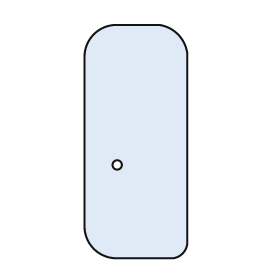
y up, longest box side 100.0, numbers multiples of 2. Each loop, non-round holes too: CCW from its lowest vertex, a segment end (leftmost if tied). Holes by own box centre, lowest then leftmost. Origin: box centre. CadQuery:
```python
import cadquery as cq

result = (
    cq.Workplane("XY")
    .moveTo(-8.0, -50.0)
    .lineTo(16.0, -50.0)
    .threePointArc((20.0, -48.0), (22.0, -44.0))
    .lineTo(22.0, 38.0)
    .threePointArc((18.0, 46.0), (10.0, 50.0))
    .lineTo(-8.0, 50.0)
    .threePointArc((-18.0, 46.0), (-22.0, 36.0))
    .lineTo(-22.0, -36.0)
    .threePointArc((-18.0, -46.0), (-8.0, -50.0))
    .close()
    .moveTo(-8.0, -10.0)
    .circle(2.0)
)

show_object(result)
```